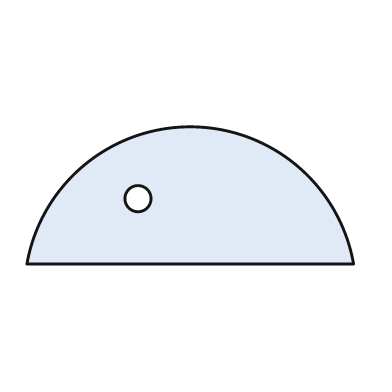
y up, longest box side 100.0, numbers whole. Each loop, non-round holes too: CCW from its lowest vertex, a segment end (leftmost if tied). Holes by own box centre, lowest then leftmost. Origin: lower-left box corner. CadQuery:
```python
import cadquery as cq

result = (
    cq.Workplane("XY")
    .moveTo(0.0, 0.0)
    .lineTo(100.0, 0.0)
    .threePointArc((50.0, 42.0), (0.0, 0.0))
    .close()
    .moveTo(34.0, 20.0)
    .circle(4.0)
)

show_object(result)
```